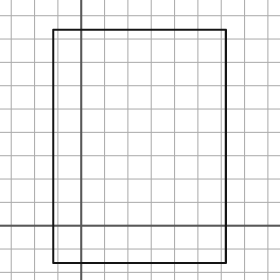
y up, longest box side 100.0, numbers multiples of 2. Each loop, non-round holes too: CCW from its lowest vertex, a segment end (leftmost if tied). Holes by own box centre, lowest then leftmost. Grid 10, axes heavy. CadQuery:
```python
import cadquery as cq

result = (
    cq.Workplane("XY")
    .moveTo(-12.0, -16.0)
    .lineTo(62.0, -16.0)
    .lineTo(62.0, 84.0)
    .lineTo(-12.0, 84.0)
    .close()
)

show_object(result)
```